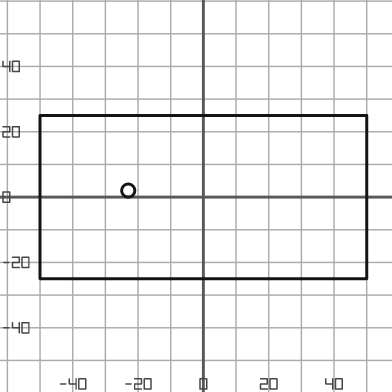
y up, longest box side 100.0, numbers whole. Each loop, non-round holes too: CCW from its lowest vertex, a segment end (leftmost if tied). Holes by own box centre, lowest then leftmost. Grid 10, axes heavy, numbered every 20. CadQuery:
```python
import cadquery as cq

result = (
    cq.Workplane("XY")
    .moveTo(-50.0, -25.0)
    .lineTo(50.0, -25.0)
    .lineTo(50.0, 25.0)
    .lineTo(-50.0, 25.0)
    .close()
    .moveTo(-23.0, 2.0)
    .circle(2.0)
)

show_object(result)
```